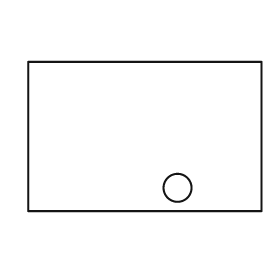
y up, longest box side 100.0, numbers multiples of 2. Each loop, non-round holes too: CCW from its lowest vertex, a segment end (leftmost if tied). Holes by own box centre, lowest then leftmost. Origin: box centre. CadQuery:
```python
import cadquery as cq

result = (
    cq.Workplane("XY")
    .moveTo(-50.0, -32.0)
    .lineTo(50.0, -32.0)
    .lineTo(50.0, 32.0)
    .lineTo(-50.0, 32.0)
    .close()
    .moveTo(14.0, -22.0)
    .circle(6.0)
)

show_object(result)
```